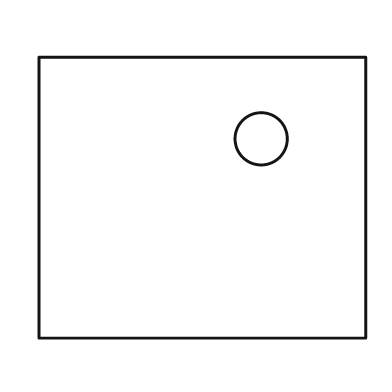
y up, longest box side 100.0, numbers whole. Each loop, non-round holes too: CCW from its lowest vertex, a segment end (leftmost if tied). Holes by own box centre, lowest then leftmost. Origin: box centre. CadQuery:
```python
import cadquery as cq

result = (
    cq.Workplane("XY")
    .moveTo(-50.0, -43.0)
    .lineTo(50.0, -43.0)
    .lineTo(50.0, 43.0)
    .lineTo(-50.0, 43.0)
    .close()
    .moveTo(18.0, 18.0)
    .circle(8.0)
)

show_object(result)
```